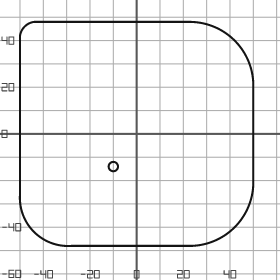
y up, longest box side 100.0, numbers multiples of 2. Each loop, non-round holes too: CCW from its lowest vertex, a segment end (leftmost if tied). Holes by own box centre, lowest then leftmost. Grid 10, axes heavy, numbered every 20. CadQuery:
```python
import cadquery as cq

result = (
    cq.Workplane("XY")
    .moveTo(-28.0, -48.0)
    .lineTo(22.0, -48.0)
    .threePointArc((42.0, -40.0), (50.0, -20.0))
    .lineTo(50.0, 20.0)
    .threePointArc((42.0, 40.0), (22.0, 48.0))
    .lineTo(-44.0, 48.0)
    .threePointArc((-48.0, 46.0), (-50.0, 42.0))
    .lineTo(-50.0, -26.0)
    .threePointArc((-44.0, -42.0), (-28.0, -48.0))
    .close()
    .moveTo(-10.0, -14.0)
    .circle(2.0)
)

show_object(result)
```